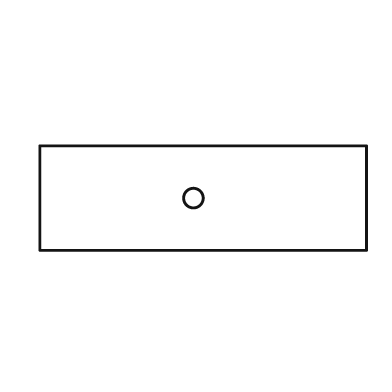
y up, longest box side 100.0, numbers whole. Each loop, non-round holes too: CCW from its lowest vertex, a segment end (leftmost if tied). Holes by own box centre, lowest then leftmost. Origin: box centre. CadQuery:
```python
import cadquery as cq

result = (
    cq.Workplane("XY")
    .moveTo(-50.0, -16.0)
    .lineTo(50.0, -16.0)
    .lineTo(50.0, 16.0)
    .lineTo(-50.0, 16.0)
    .close()
    .moveTo(-3.0, 0.0)
    .circle(3.0)
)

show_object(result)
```